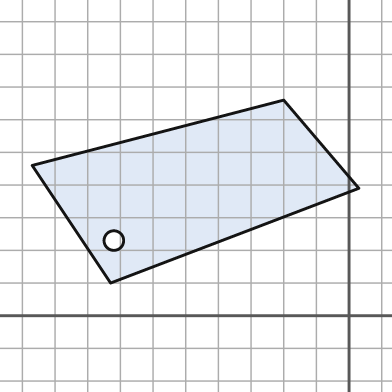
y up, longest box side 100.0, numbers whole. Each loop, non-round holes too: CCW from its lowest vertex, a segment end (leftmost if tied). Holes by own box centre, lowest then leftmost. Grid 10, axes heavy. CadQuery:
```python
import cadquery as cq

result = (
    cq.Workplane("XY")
    .moveTo(-73.0, 10.0)
    .lineTo(3.0, 39.0)
    .lineTo(-20.0, 66.0)
    .lineTo(-97.0, 46.0)
    .close()
    .moveTo(-72.0, 23.0)
    .circle(3.0)
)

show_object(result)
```